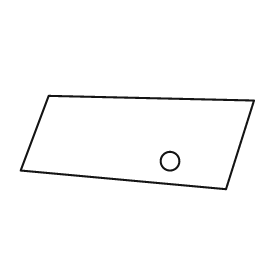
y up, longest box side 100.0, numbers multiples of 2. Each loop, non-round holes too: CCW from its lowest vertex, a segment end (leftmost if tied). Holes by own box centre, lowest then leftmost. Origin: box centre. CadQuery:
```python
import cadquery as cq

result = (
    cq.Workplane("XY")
    .moveTo(38.0, -20.0)
    .lineTo(50.0, 18.0)
    .lineTo(-38.0, 20.0)
    .lineTo(-50.0, -12.0)
    .close()
    .moveTo(14.0, -8.0)
    .circle(4.0)
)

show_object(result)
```